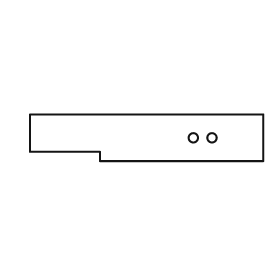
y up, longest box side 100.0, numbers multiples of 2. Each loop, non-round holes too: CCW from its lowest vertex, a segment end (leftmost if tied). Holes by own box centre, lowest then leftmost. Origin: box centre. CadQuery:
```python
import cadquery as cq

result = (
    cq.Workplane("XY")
    .moveTo(-20.0, -10.0)
    .lineTo(50.0, -10.0)
    .lineTo(50.0, 10.0)
    .lineTo(-50.0, 10.0)
    .lineTo(-50.0, -6.0)
    .lineTo(-20.0, -6.0)
    .close()
    .moveTo(20.0, 0.0)
    .circle(2.0)
    .moveTo(28.0, 0.0)
    .circle(2.0)
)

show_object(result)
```